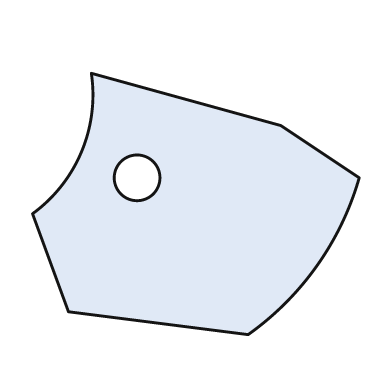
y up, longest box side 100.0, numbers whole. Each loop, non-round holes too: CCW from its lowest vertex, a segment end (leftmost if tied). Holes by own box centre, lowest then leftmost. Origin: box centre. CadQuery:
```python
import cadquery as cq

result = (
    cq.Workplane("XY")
    .moveTo(16.0, -40.0)
    .threePointArc((37.0, -19.0), (50.0, 8.0))
    .lineTo(26.0, 24.0)
    .lineTo(-32.0, 40.0)
    .threePointArc((-35.0, 16.0), (-50.0, -3.0))
    .lineTo(-39.0, -33.0)
    .close()
    .moveTo(-18.0, 8.0)
    .circle(7.0)
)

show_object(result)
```